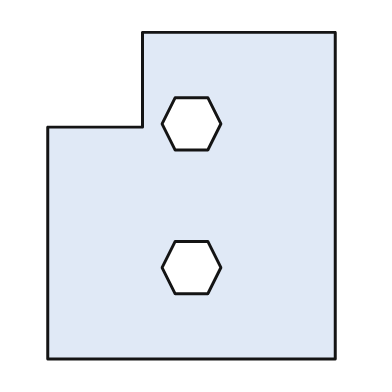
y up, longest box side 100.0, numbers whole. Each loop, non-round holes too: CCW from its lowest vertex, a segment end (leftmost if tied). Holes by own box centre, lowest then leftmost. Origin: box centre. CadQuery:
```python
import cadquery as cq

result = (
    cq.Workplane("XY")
    .moveTo(-44.0, -50.0)
    .lineTo(44.0, -50.0)
    .lineTo(44.0, 50.0)
    .lineTo(-15.0, 50.0)
    .lineTo(-15.0, 21.0)
    .lineTo(-44.0, 21.0)
    .close()
    .moveTo(-5.0, -30.0)
    .lineTo(5.0, -30.0)
    .lineTo(9.0, -22.0)
    .lineTo(5.0, -14.0)
    .lineTo(-5.0, -14.0)
    .lineTo(-9.0, -22.0)
    .close()
    .moveTo(-5.0, 14.0)
    .lineTo(5.0, 14.0)
    .lineTo(9.0, 22.0)
    .lineTo(5.0, 30.0)
    .lineTo(-5.0, 30.0)
    .lineTo(-9.0, 22.0)
    .close()
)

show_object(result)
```